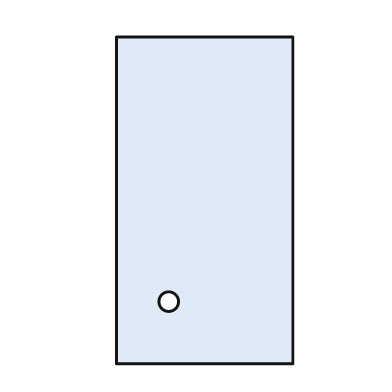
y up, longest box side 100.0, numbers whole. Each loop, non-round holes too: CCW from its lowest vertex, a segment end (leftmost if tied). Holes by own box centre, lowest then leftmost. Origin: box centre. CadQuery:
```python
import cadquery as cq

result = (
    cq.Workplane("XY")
    .moveTo(-27.0, -50.0)
    .lineTo(27.0, -50.0)
    .lineTo(27.0, 50.0)
    .lineTo(-27.0, 50.0)
    .close()
    .moveTo(-11.0, -31.0)
    .circle(3.0)
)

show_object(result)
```